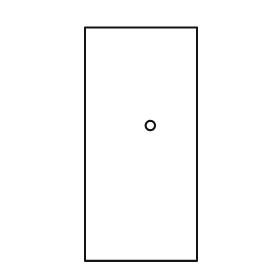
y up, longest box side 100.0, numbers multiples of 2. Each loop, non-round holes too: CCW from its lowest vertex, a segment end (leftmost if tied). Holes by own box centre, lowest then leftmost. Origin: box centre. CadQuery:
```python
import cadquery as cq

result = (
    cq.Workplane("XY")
    .moveTo(-24.0, -50.0)
    .lineTo(24.0, -50.0)
    .lineTo(24.0, 50.0)
    .lineTo(-24.0, 50.0)
    .close()
    .moveTo(4.0, 8.0)
    .circle(2.0)
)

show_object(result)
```